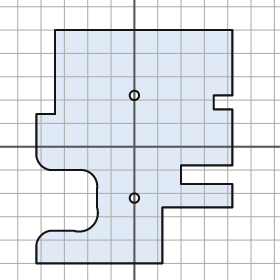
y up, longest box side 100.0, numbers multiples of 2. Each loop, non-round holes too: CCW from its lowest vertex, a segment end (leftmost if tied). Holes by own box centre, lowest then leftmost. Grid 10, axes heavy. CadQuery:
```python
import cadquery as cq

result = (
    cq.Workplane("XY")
    .moveTo(-42.0, -50.0)
    .lineTo(12.0, -50.0)
    .lineTo(12.0, -26.0)
    .lineTo(42.0, -26.0)
    .lineTo(42.0, -16.0)
    .lineTo(20.0, -16.0)
    .lineTo(20.0, -8.0)
    .lineTo(42.0, -8.0)
    .lineTo(42.0, 16.0)
    .lineTo(34.0, 16.0)
    .lineTo(34.0, 22.0)
    .lineTo(42.0, 22.0)
    .lineTo(42.0, 50.0)
    .lineTo(-34.0, 50.0)
    .lineTo(-34.0, 14.0)
    .lineTo(-42.0, 14.0)
    .lineTo(-42.0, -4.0)
    .threePointArc((-40.0, -8.0), (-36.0, -10.0))
    .lineTo(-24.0, -10.0)
    .threePointArc((-18.0, -12.0), (-16.0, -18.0))
    .lineTo(-16.0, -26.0)
    .threePointArc((-18.0, -34.0), (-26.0, -36.0))
    .lineTo(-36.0, -36.0)
    .threePointArc((-40.0, -38.0), (-42.0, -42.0))
    .close()
    .moveTo(0.0, -22.0)
    .circle(2.0)
    .moveTo(0.0, 22.0)
    .circle(2.0)
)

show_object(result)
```